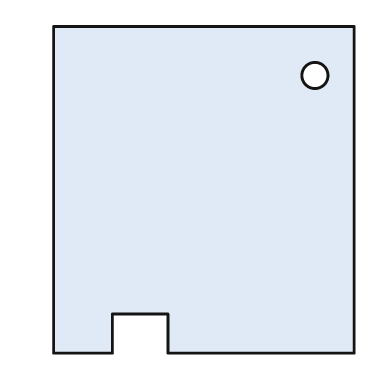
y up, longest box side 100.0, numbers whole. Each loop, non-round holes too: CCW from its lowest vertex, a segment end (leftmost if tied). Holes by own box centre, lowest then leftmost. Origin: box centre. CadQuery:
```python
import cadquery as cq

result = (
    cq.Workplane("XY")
    .moveTo(-46.0, -50.0)
    .lineTo(-28.0, -50.0)
    .lineTo(-28.0, -38.0)
    .lineTo(-11.0, -38.0)
    .lineTo(-11.0, -50.0)
    .lineTo(46.0, -50.0)
    .lineTo(46.0, 50.0)
    .lineTo(-46.0, 50.0)
    .close()
    .moveTo(34.0, 35.0)
    .circle(4.0)
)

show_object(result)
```